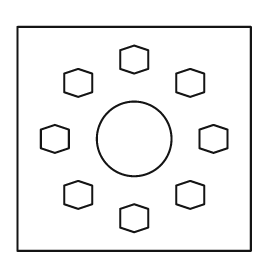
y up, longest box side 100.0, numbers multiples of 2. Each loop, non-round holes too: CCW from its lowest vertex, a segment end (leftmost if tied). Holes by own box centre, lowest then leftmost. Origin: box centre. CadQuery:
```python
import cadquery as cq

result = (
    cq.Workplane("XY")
    .moveTo(-50.0, -48.0)
    .lineTo(50.0, -48.0)
    .lineTo(50.0, 48.0)
    .lineTo(-50.0, 48.0)
    .close()
    .moveTo(0.0, -40.0)
    .lineTo(6.0, -38.0)
    .lineTo(6.0, -30.0)
    .lineTo(0.0, -28.0)
    .lineTo(-6.0, -30.0)
    .lineTo(-6.0, -38.0)
    .close()
    .moveTo(-24.0, -30.0)
    .lineTo(-18.0, -28.0)
    .lineTo(-18.0, -20.0)
    .lineTo(-24.0, -18.0)
    .lineTo(-30.0, -20.0)
    .lineTo(-30.0, -28.0)
    .close()
    .moveTo(24.0, -30.0)
    .lineTo(30.0, -28.0)
    .lineTo(30.0, -20.0)
    .lineTo(24.0, -18.0)
    .lineTo(18.0, -20.0)
    .lineTo(18.0, -28.0)
    .close()
    .moveTo(-34.0, -6.0)
    .lineTo(-28.0, -4.0)
    .lineTo(-28.0, 4.0)
    .lineTo(-34.0, 6.0)
    .lineTo(-40.0, 4.0)
    .lineTo(-40.0, -4.0)
    .close()
    .moveTo(0.0, 0.0)
    .circle(16.0)
    .moveTo(34.0, -6.0)
    .lineTo(40.0, -4.0)
    .lineTo(40.0, 4.0)
    .lineTo(34.0, 6.0)
    .lineTo(28.0, 4.0)
    .lineTo(28.0, -4.0)
    .close()
    .moveTo(-24.0, 18.0)
    .lineTo(-18.0, 20.0)
    .lineTo(-18.0, 28.0)
    .lineTo(-24.0, 30.0)
    .lineTo(-30.0, 28.0)
    .lineTo(-30.0, 20.0)
    .close()
    .moveTo(24.0, 18.0)
    .lineTo(30.0, 20.0)
    .lineTo(30.0, 28.0)
    .lineTo(24.0, 30.0)
    .lineTo(18.0, 28.0)
    .lineTo(18.0, 20.0)
    .close()
    .moveTo(0.0, 28.0)
    .lineTo(6.0, 30.0)
    .lineTo(6.0, 38.0)
    .lineTo(0.0, 40.0)
    .lineTo(-6.0, 38.0)
    .lineTo(-6.0, 30.0)
    .close()
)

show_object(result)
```